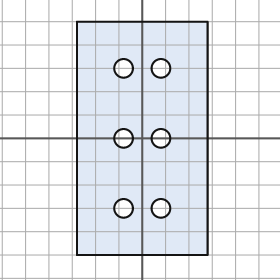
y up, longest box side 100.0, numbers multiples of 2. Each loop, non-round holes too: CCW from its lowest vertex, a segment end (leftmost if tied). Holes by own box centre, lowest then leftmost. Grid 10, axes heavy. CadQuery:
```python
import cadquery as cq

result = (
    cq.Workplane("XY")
    .moveTo(-28.0, -50.0)
    .lineTo(28.0, -50.0)
    .lineTo(28.0, 50.0)
    .lineTo(-28.0, 50.0)
    .close()
    .moveTo(-8.0, -30.0)
    .circle(4.0)
    .moveTo(8.0, -30.0)
    .circle(4.0)
    .moveTo(-8.0, 0.0)
    .circle(4.0)
    .moveTo(8.0, 0.0)
    .circle(4.0)
    .moveTo(-8.0, 30.0)
    .circle(4.0)
    .moveTo(8.0, 30.0)
    .circle(4.0)
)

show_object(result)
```